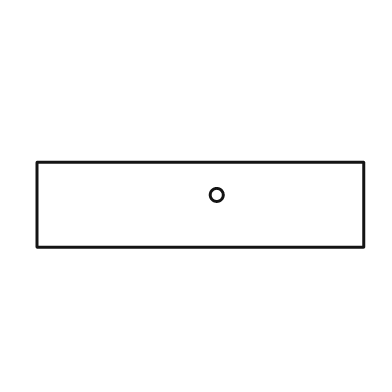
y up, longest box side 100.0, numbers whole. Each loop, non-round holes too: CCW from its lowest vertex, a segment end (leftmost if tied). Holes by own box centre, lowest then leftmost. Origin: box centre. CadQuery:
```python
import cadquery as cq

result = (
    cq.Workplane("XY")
    .moveTo(-50.0, -13.0)
    .lineTo(50.0, -13.0)
    .lineTo(50.0, 13.0)
    .lineTo(-50.0, 13.0)
    .close()
    .moveTo(5.0, 3.0)
    .circle(2.0)
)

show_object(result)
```